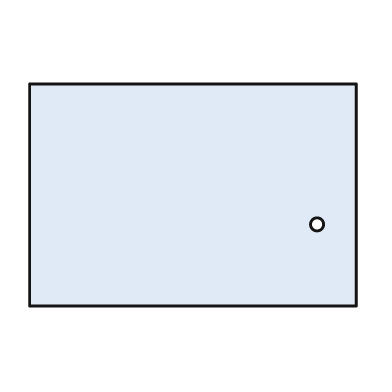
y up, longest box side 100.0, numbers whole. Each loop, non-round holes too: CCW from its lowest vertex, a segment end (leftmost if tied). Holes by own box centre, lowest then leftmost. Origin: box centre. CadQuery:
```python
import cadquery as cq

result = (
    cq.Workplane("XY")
    .moveTo(-50.0, -34.0)
    .lineTo(50.0, -34.0)
    .lineTo(50.0, 34.0)
    .lineTo(-50.0, 34.0)
    .close()
    .moveTo(38.0, -9.0)
    .circle(2.0)
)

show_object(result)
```